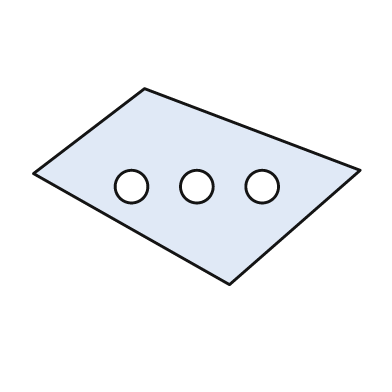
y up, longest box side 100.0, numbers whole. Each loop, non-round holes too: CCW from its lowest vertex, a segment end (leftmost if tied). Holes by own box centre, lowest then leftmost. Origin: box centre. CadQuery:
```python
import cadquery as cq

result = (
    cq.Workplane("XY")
    .moveTo(10.0, -30.0)
    .lineTo(50.0, 5.0)
    .lineTo(-16.0, 30.0)
    .lineTo(-50.0, 4.0)
    .close()
    .moveTo(-20.0, 0.0)
    .circle(5.0)
    .moveTo(0.0, 0.0)
    .circle(5.0)
    .moveTo(20.0, 0.0)
    .circle(5.0)
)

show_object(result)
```